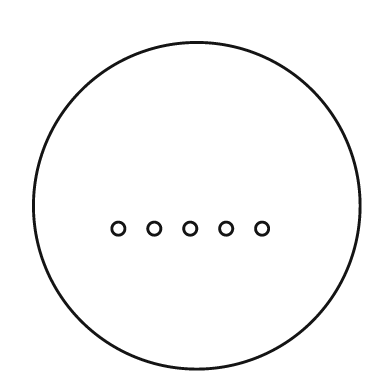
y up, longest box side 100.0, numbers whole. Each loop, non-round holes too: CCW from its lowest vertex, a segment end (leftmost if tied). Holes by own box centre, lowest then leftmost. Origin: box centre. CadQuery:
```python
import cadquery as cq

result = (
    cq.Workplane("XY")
    .moveTo(0.0, 0.0)
    .circle(50.0)
    .moveTo(-24.0, -7.0)
    .circle(2.0)
    .moveTo(-13.0, -7.0)
    .circle(2.0)
    .moveTo(-2.0, -7.0)
    .circle(2.0)
    .moveTo(9.0, -7.0)
    .circle(2.0)
    .moveTo(20.0, -7.0)
    .circle(2.0)
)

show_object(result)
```